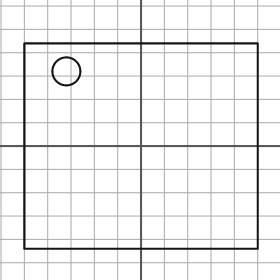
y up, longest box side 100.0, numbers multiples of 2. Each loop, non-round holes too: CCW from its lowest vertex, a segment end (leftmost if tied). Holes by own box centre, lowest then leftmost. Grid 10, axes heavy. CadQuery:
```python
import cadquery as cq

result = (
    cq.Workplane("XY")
    .moveTo(-50.0, -44.0)
    .lineTo(50.0, -44.0)
    .lineTo(50.0, 44.0)
    .lineTo(-50.0, 44.0)
    .close()
    .moveTo(-32.0, 32.0)
    .circle(6.0)
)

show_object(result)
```